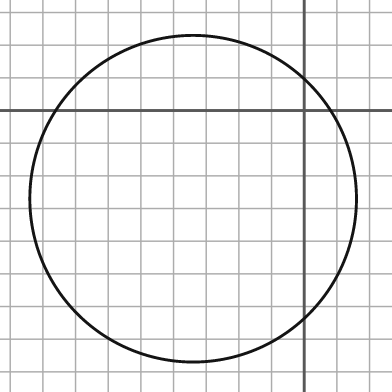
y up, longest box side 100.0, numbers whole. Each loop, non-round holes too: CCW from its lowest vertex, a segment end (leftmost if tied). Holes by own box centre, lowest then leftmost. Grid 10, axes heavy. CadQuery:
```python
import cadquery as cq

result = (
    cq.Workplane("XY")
    .moveTo(-34.0, -27.0)
    .circle(50.0)
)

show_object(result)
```